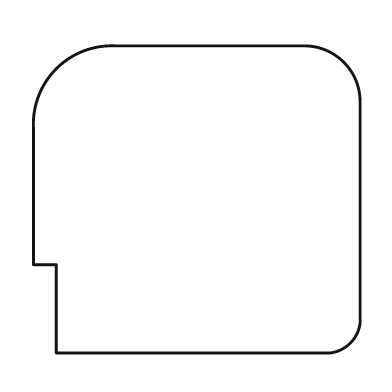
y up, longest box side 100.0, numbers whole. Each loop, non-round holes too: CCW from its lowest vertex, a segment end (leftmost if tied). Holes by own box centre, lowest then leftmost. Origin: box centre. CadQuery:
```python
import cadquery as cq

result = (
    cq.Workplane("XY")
    .moveTo(-43.0, -47.0)
    .lineTo(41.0, -47.0)
    .threePointArc((47.0, -44.0), (50.0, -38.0))
    .lineTo(50.0, 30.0)
    .threePointArc((45.0, 42.0), (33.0, 47.0))
    .lineTo(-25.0, 47.0)
    .threePointArc((-43.0, 40.0), (-50.0, 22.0))
    .lineTo(-50.0, -20.0)
    .lineTo(-43.0, -20.0)
    .close()
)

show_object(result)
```